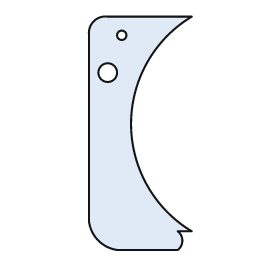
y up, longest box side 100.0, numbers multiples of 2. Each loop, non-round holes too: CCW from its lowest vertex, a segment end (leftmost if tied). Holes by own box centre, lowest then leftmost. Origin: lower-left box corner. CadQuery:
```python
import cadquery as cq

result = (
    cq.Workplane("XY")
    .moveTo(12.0, 0.0)
    .lineTo(38.0, 0.0)
    .threePointArc((40.0, 4.0), (38.0, 8.0))
    .lineTo(44.0, 8.0)
    .threePointArc((18.0, 54.0), (44.0, 100.0))
    .lineTo(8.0, 100.0)
    .threePointArc((2.0, 98.0), (0.0, 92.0))
    .lineTo(0.0, 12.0)
    .threePointArc((4.0, 4.0), (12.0, 0.0))
    .close()
    .moveTo(8.0, 76.0)
    .circle(4.0)
    .moveTo(14.0, 92.0)
    .circle(2.0)
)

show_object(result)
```